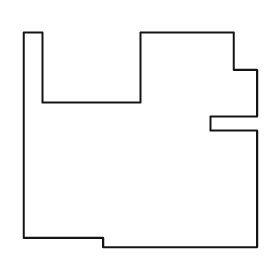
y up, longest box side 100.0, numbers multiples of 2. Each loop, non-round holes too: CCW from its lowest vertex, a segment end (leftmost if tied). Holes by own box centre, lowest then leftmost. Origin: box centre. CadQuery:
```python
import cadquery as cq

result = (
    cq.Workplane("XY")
    .moveTo(-16.0, -46.0)
    .lineTo(50.0, -46.0)
    .lineTo(50.0, 4.0)
    .lineTo(30.0, 4.0)
    .lineTo(30.0, 10.0)
    .lineTo(50.0, 10.0)
    .lineTo(50.0, 30.0)
    .lineTo(40.0, 30.0)
    .lineTo(40.0, 46.0)
    .lineTo(0.0, 46.0)
    .lineTo(0.0, 16.0)
    .lineTo(-42.0, 16.0)
    .lineTo(-42.0, 46.0)
    .lineTo(-50.0, 46.0)
    .lineTo(-50.0, -42.0)
    .lineTo(-16.0, -42.0)
    .close()
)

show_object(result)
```